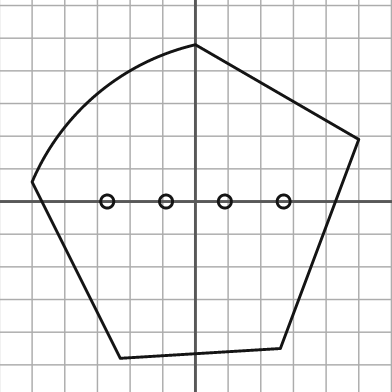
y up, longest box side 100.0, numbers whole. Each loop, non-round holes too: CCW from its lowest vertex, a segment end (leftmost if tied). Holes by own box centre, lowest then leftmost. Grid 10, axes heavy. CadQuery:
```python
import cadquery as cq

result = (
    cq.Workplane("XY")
    .moveTo(-23.0, -48.0)
    .lineTo(26.0, -45.0)
    .lineTo(50.0, 19.0)
    .lineTo(0.0, 48.0)
    .threePointArc((-30.0, 33.0), (-50.0, 6.0))
    .close()
    .moveTo(-27.0, 0.0)
    .circle(2.0)
    .moveTo(-9.0, 0.0)
    .circle(2.0)
    .moveTo(9.0, 0.0)
    .circle(2.0)
    .moveTo(27.0, 0.0)
    .circle(2.0)
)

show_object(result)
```